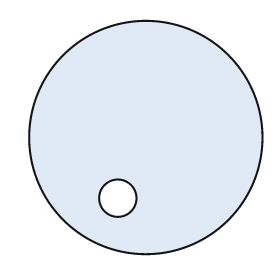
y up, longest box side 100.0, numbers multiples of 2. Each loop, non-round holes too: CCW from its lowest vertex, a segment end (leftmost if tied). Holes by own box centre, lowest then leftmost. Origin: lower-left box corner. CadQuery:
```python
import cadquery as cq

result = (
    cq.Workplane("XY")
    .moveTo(50.0, 50.0)
    .circle(50.0)
    .moveTo(38.0, 24.0)
    .circle(8.0)
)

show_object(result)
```